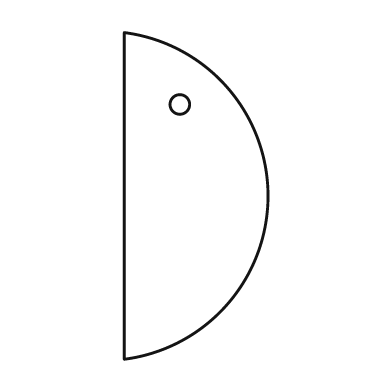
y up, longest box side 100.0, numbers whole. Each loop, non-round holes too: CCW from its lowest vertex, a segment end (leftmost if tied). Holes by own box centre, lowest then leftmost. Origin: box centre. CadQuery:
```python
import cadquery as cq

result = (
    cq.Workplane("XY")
    .moveTo(-22.0, -50.0)
    .threePointArc((22.0, 0.0), (-22.0, 50.0))
    .close()
    .moveTo(-5.0, 28.0)
    .circle(3.0)
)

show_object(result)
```